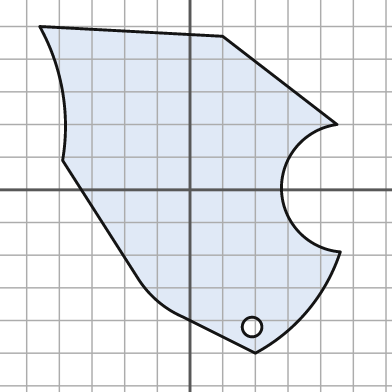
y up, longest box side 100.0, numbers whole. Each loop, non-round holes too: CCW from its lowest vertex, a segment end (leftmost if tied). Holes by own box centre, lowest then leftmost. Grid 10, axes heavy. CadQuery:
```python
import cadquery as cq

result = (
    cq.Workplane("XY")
    .moveTo(20.0, -50.0)
    .threePointArc((36.0, -37.0), (46.0, -19.0))
    .threePointArc((28.0, 0.0), (45.0, 20.0))
    .lineTo(10.0, 47.0)
    .lineTo(-46.0, 50.0)
    .threePointArc((-39.0, 30.0), (-39.0, 9.0))
    .lineTo(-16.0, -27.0)
    .threePointArc((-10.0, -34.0), (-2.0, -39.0))
    .close()
    .moveTo(19.0, -42.0)
    .circle(3.0)
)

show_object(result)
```